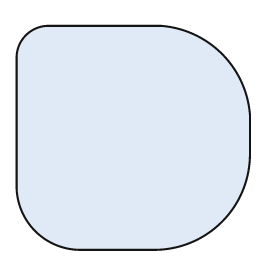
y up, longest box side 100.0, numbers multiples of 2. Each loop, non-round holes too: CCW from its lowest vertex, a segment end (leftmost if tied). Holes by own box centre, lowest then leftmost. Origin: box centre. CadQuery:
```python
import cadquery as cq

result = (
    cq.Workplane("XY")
    .moveTo(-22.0, -48.0)
    .lineTo(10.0, -48.0)
    .threePointArc((38.0, -36.0), (50.0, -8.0))
    .lineTo(50.0, 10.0)
    .threePointArc((38.0, 36.0), (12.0, 48.0))
    .lineTo(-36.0, 48.0)
    .threePointArc((-46.0, 44.0), (-50.0, 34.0))
    .lineTo(-50.0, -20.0)
    .threePointArc((-42.0, -40.0), (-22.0, -48.0))
    .close()
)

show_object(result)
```